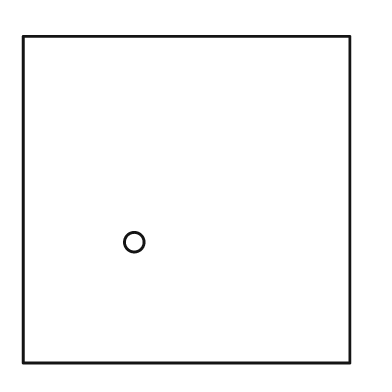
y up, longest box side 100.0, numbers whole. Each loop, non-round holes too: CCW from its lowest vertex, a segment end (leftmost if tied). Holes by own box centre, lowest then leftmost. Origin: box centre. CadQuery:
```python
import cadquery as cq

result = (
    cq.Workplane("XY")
    .moveTo(-50.0, -50.0)
    .lineTo(50.0, -50.0)
    .lineTo(50.0, 50.0)
    .lineTo(-50.0, 50.0)
    .close()
    .moveTo(-16.0, -13.0)
    .circle(3.0)
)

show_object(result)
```